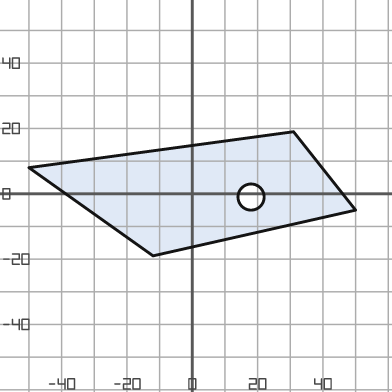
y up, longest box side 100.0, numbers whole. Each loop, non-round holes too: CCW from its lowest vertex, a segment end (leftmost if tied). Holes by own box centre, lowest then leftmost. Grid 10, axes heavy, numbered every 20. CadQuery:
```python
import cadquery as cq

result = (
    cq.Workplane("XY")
    .moveTo(-12.0, -19.0)
    .lineTo(50.0, -5.0)
    .lineTo(31.0, 19.0)
    .lineTo(-50.0, 8.0)
    .close()
    .moveTo(18.0, -1.0)
    .circle(4.0)
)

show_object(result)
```